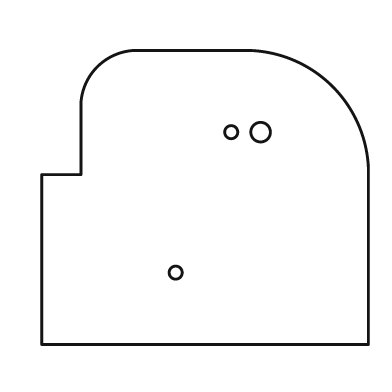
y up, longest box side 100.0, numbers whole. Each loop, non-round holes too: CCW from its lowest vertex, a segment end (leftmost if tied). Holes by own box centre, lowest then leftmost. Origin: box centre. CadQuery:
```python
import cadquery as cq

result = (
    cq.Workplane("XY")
    .moveTo(-50.0, -45.0)
    .lineTo(50.0, -45.0)
    .lineTo(50.0, 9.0)
    .threePointArc((39.0, 34.0), (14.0, 45.0))
    .lineTo(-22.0, 45.0)
    .threePointArc((-33.0, 40.0), (-38.0, 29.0))
    .lineTo(-38.0, 7.0)
    .lineTo(-50.0, 7.0)
    .close()
    .moveTo(-9.0, -23.0)
    .circle(2.0)
    .moveTo(8.0, 20.0)
    .circle(2.0)
    .moveTo(17.0, 20.0)
    .circle(3.0)
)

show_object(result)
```